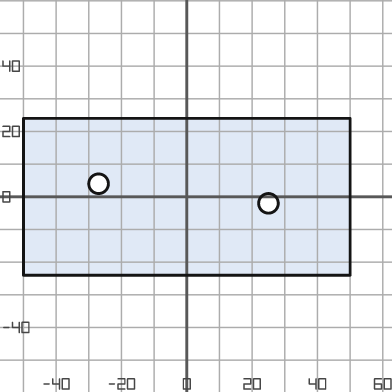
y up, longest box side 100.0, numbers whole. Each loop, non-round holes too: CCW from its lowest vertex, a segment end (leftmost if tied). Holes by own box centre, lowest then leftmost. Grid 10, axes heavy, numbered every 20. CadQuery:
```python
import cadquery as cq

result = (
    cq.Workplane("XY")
    .moveTo(-50.0, -24.0)
    .lineTo(50.0, -24.0)
    .lineTo(50.0, 24.0)
    .lineTo(-50.0, 24.0)
    .close()
    .moveTo(25.0, -2.0)
    .circle(3.0)
    .moveTo(-27.0, 4.0)
    .circle(3.0)
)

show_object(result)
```